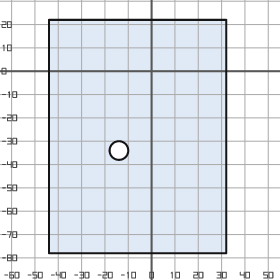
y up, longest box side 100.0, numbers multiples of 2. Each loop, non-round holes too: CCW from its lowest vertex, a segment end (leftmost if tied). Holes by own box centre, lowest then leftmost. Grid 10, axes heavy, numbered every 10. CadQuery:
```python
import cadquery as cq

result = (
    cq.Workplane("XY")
    .moveTo(-44.0, -78.0)
    .lineTo(32.0, -78.0)
    .lineTo(32.0, 22.0)
    .lineTo(-44.0, 22.0)
    .close()
    .moveTo(-14.0, -34.0)
    .circle(4.0)
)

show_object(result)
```